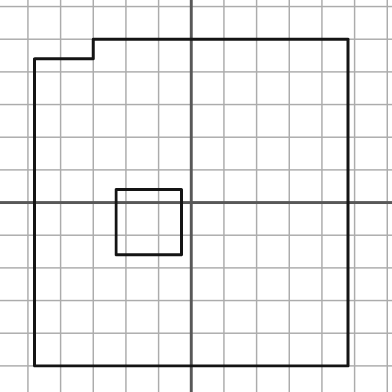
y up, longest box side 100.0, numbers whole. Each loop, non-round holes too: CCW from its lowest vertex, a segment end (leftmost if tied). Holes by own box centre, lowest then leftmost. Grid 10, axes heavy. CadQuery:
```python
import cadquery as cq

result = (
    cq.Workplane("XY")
    .moveTo(-48.0, -50.0)
    .lineTo(48.0, -50.0)
    .lineTo(48.0, 50.0)
    .lineTo(-30.0, 50.0)
    .lineTo(-30.0, 44.0)
    .lineTo(-48.0, 44.0)
    .close()
    .moveTo(-23.0, -16.0)
    .lineTo(-3.0, -16.0)
    .lineTo(-3.0, 4.0)
    .lineTo(-23.0, 4.0)
    .close()
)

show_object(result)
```